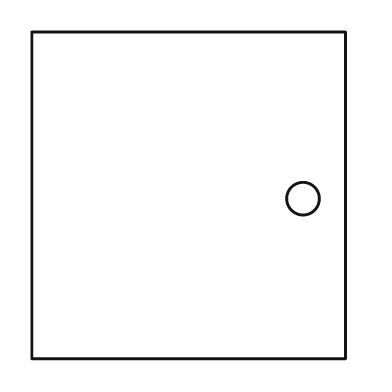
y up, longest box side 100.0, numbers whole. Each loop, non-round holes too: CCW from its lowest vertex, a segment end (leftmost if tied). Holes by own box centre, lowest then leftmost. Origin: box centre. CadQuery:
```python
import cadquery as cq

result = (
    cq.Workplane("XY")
    .moveTo(-48.0, -50.0)
    .lineTo(48.0, -50.0)
    .lineTo(48.0, 50.0)
    .lineTo(-48.0, 50.0)
    .close()
    .moveTo(35.0, -1.0)
    .circle(5.0)
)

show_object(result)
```